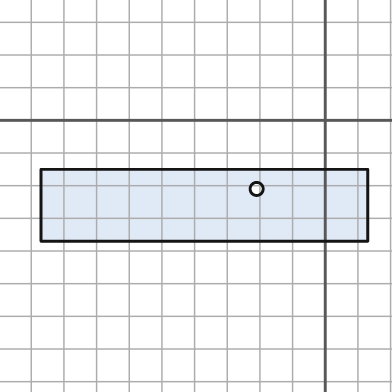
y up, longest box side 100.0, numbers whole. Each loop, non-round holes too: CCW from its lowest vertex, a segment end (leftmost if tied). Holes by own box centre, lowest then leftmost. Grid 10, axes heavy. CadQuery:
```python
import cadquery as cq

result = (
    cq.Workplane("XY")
    .moveTo(-87.0, -37.0)
    .lineTo(13.0, -37.0)
    .lineTo(13.0, -15.0)
    .lineTo(-87.0, -15.0)
    .close()
    .moveTo(-21.0, -21.0)
    .circle(2.0)
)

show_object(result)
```